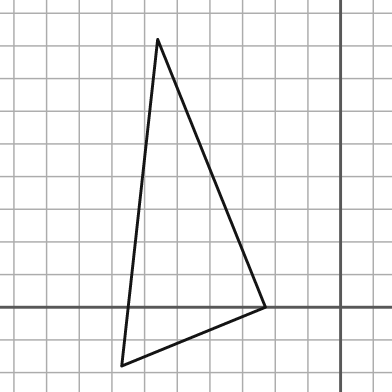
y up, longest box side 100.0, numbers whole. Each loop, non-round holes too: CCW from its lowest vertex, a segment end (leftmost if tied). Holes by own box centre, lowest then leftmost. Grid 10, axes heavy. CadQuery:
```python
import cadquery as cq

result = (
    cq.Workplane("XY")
    .moveTo(-67.0, -18.0)
    .lineTo(-23.0, 0.0)
    .lineTo(-56.0, 82.0)
    .close()
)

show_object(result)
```